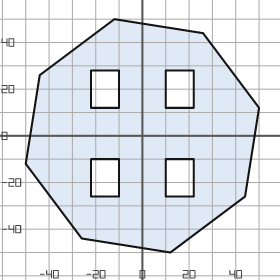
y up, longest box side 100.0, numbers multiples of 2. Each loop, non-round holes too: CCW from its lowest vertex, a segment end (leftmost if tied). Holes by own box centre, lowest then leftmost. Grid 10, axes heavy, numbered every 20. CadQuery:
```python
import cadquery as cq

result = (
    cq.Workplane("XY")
    .moveTo(12.0, -50.0)
    .lineTo(44.0, -26.0)
    .lineTo(50.0, 12.0)
    .lineTo(26.0, 44.0)
    .lineTo(-12.0, 50.0)
    .lineTo(-44.0, 26.0)
    .lineTo(-50.0, -12.0)
    .lineTo(-26.0, -44.0)
    .close()
    .moveTo(-22.0, -26.0)
    .lineTo(-10.0, -26.0)
    .lineTo(-10.0, -10.0)
    .lineTo(-22.0, -10.0)
    .close()
    .moveTo(10.0, -26.0)
    .lineTo(22.0, -26.0)
    .lineTo(22.0, -10.0)
    .lineTo(10.0, -10.0)
    .close()
    .moveTo(-22.0, 12.0)
    .lineTo(-10.0, 12.0)
    .lineTo(-10.0, 28.0)
    .lineTo(-22.0, 28.0)
    .close()
    .moveTo(10.0, 12.0)
    .lineTo(22.0, 12.0)
    .lineTo(22.0, 28.0)
    .lineTo(10.0, 28.0)
    .close()
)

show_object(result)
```